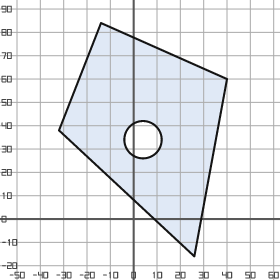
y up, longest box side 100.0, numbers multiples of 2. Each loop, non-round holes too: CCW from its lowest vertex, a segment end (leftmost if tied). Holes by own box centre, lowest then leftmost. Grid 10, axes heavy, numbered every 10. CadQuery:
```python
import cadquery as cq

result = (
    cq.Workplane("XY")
    .moveTo(26.0, -16.0)
    .lineTo(40.0, 60.0)
    .lineTo(-14.0, 84.0)
    .lineTo(-32.0, 38.0)
    .close()
    .moveTo(4.0, 34.0)
    .circle(8.0)
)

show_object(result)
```